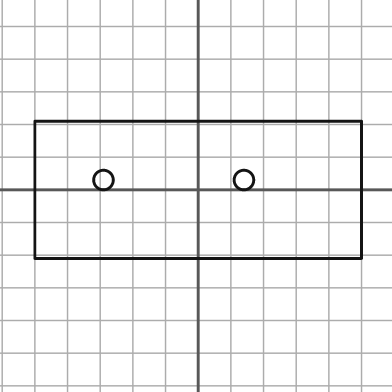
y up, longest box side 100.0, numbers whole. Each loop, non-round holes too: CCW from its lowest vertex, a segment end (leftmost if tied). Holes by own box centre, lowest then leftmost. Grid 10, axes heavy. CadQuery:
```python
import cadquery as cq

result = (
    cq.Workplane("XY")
    .moveTo(-50.0, -21.0)
    .lineTo(50.0, -21.0)
    .lineTo(50.0, 21.0)
    .lineTo(-50.0, 21.0)
    .close()
    .moveTo(-29.0, 3.0)
    .circle(3.0)
    .moveTo(14.0, 3.0)
    .circle(3.0)
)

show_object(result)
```